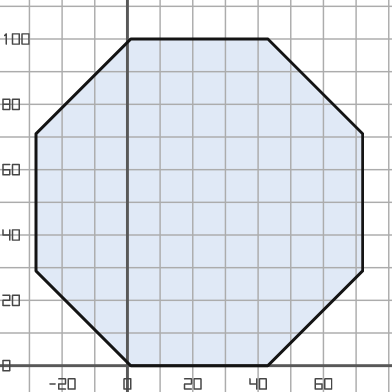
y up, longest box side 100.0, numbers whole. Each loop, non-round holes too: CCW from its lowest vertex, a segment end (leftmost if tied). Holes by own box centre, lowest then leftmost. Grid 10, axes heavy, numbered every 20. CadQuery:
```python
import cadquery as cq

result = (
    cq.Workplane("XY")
    .moveTo(1.0, 0.0)
    .lineTo(43.0, 0.0)
    .lineTo(72.0, 29.0)
    .lineTo(72.0, 71.0)
    .lineTo(43.0, 100.0)
    .lineTo(1.0, 100.0)
    .lineTo(-28.0, 71.0)
    .lineTo(-28.0, 29.0)
    .close()
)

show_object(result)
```